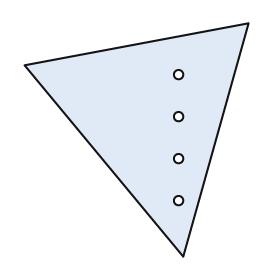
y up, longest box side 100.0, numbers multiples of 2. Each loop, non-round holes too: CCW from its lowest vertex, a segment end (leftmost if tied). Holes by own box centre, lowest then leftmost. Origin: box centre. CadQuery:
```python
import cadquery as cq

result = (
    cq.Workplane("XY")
    .moveTo(20.0, -50.0)
    .lineTo(48.0, 50.0)
    .lineTo(-48.0, 32.0)
    .close()
    .moveTo(18.0, -26.0)
    .circle(2.0)
    .moveTo(18.0, -8.0)
    .circle(2.0)
    .moveTo(18.0, 10.0)
    .circle(2.0)
    .moveTo(18.0, 28.0)
    .circle(2.0)
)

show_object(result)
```